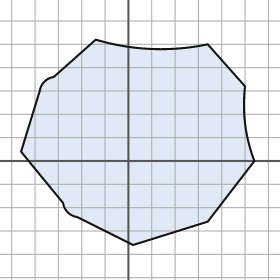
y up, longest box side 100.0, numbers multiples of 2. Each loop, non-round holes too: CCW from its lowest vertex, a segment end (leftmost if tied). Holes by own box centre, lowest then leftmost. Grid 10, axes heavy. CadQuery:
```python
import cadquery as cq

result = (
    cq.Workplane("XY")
    .moveTo(2.0, -36.0)
    .lineTo(34.0, -26.0)
    .lineTo(54.0, 0.0)
    .threePointArc((50.0, 16.0), (50.0, 32.0))
    .lineTo(34.0, 50.0)
    .threePointArc((10.0, 48.0), (-14.0, 52.0))
    .lineTo(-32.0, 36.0)
    .threePointArc((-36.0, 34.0), (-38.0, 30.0))
    .lineTo(-46.0, 4.0)
    .lineTo(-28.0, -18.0)
    .threePointArc((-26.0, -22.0), (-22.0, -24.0))
    .close()
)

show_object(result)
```